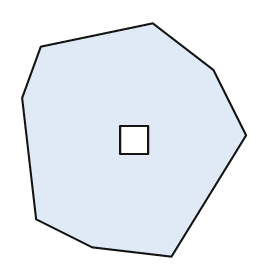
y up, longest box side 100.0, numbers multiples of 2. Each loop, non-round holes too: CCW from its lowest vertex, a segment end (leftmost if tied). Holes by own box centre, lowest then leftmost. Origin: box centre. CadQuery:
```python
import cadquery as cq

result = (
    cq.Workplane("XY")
    .moveTo(16.0, -50.0)
    .lineTo(48.0, 2.0)
    .lineTo(34.0, 30.0)
    .lineTo(8.0, 50.0)
    .lineTo(-40.0, 40.0)
    .lineTo(-48.0, 18.0)
    .lineTo(-42.0, -34.0)
    .lineTo(-18.0, -46.0)
    .close()
    .moveTo(-6.0, -6.0)
    .lineTo(6.0, -6.0)
    .lineTo(6.0, 6.0)
    .lineTo(-6.0, 6.0)
    .close()
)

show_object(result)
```